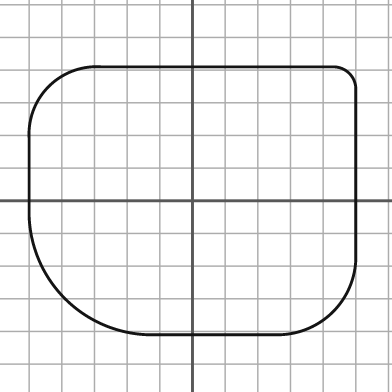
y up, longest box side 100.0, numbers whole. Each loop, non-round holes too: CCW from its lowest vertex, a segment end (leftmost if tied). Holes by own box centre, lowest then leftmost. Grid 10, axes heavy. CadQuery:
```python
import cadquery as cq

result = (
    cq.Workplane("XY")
    .moveTo(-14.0, -41.0)
    .lineTo(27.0, -41.0)
    .threePointArc((43.0, -34.0), (50.0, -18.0))
    .lineTo(50.0, 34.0)
    .threePointArc((48.0, 39.0), (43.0, 41.0))
    .lineTo(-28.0, 41.0)
    .threePointArc((-44.0, 35.0), (-50.0, 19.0))
    .lineTo(-50.0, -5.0)
    .threePointArc((-39.0, -30.0), (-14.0, -41.0))
    .close()
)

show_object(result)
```